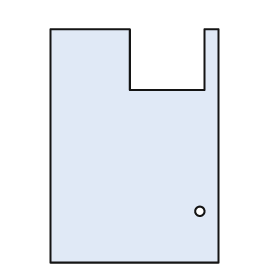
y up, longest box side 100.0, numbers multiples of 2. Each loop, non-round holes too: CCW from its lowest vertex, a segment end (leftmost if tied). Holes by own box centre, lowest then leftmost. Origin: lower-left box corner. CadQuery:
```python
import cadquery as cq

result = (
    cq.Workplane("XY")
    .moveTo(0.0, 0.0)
    .lineTo(72.0, 0.0)
    .lineTo(72.0, 100.0)
    .lineTo(66.0, 100.0)
    .lineTo(66.0, 74.0)
    .lineTo(34.0, 74.0)
    .lineTo(34.0, 100.0)
    .lineTo(0.0, 100.0)
    .close()
    .moveTo(64.0, 22.0)
    .circle(2.0)
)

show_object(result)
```